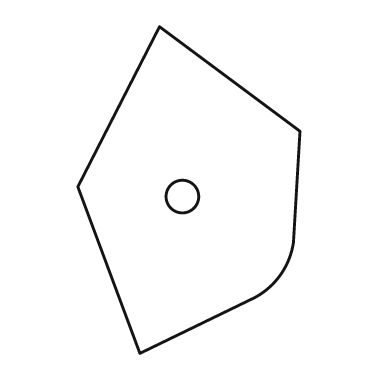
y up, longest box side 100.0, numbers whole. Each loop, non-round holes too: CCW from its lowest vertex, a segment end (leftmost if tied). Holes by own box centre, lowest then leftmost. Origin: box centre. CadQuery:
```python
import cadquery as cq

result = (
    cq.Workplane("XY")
    .moveTo(-15.0, -50.0)
    .lineTo(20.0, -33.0)
    .threePointArc((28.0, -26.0), (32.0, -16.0))
    .lineTo(34.0, 18.0)
    .lineTo(-9.0, 50.0)
    .lineTo(-34.0, 1.0)
    .close()
    .moveTo(-2.0, -2.0)
    .circle(5.0)
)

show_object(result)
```